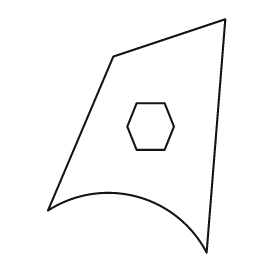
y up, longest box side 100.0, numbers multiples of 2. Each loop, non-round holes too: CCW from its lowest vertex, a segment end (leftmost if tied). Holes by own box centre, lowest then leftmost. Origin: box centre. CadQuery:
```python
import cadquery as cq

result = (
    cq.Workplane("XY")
    .moveTo(30.0, -50.0)
    .lineTo(38.0, 50.0)
    .lineTo(-10.0, 34.0)
    .lineTo(-38.0, -32.0)
    .threePointArc((0.0, -26.0), (30.0, -50.0))
    .close()
    .moveTo(0.0, -6.0)
    .lineTo(12.0, -6.0)
    .lineTo(16.0, 4.0)
    .lineTo(12.0, 14.0)
    .lineTo(0.0, 14.0)
    .lineTo(-4.0, 4.0)
    .close()
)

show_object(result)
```